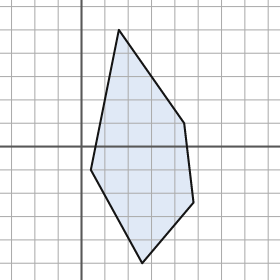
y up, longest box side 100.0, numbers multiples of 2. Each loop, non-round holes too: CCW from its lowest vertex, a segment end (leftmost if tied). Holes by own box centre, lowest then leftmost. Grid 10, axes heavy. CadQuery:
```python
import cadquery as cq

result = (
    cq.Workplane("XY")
    .moveTo(26.0, -50.0)
    .lineTo(48.0, -24.0)
    .lineTo(44.0, 10.0)
    .lineTo(16.0, 50.0)
    .lineTo(4.0, -10.0)
    .close()
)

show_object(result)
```